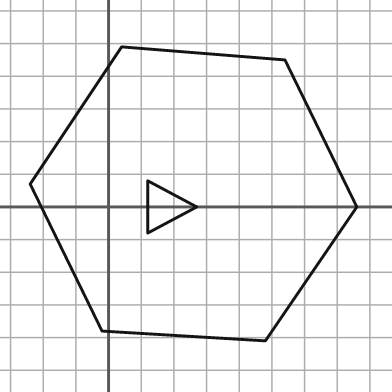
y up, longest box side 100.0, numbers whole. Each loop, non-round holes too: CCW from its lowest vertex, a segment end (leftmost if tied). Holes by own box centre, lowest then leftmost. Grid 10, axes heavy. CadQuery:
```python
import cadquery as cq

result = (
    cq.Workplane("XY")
    .moveTo(48.0, -41.0)
    .lineTo(76.0, 0.0)
    .lineTo(54.0, 45.0)
    .lineTo(4.0, 49.0)
    .lineTo(-24.0, 7.0)
    .lineTo(-2.0, -38.0)
    .close()
    .moveTo(12.0, -8.0)
    .lineTo(27.0, 0.0)
    .lineTo(12.0, 8.0)
    .close()
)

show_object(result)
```